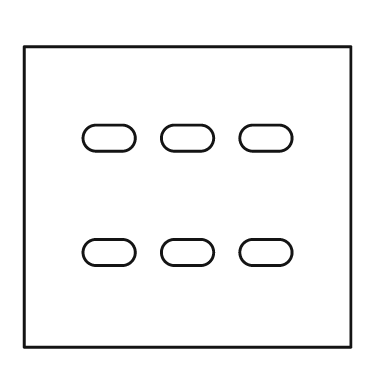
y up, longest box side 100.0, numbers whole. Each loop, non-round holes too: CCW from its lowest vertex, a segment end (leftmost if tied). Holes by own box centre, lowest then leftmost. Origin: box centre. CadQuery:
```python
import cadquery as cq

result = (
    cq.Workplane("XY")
    .moveTo(-50.0, -46.0)
    .lineTo(50.0, -46.0)
    .lineTo(50.0, 46.0)
    .lineTo(-50.0, 46.0)
    .close()
    .moveTo(-28.0, -21.0)
    .lineTo(-20.0, -21.0)
    .threePointArc((-16.0, -17.0), (-20.0, -13.0))
    .lineTo(-28.0, -13.0)
    .threePointArc((-32.0, -17.0), (-28.0, -21.0))
    .close()
    .moveTo(-4.0, -21.0)
    .lineTo(4.0, -21.0)
    .threePointArc((8.0, -17.0), (4.0, -13.0))
    .lineTo(-4.0, -13.0)
    .threePointArc((-8.0, -17.0), (-4.0, -21.0))
    .close()
    .moveTo(20.0, -21.0)
    .lineTo(28.0, -21.0)
    .threePointArc((32.0, -17.0), (28.0, -13.0))
    .lineTo(20.0, -13.0)
    .threePointArc((16.0, -17.0), (20.0, -21.0))
    .close()
    .moveTo(-28.0, 14.0)
    .lineTo(-20.0, 14.0)
    .threePointArc((-16.0, 18.0), (-20.0, 22.0))
    .lineTo(-28.0, 22.0)
    .threePointArc((-32.0, 18.0), (-28.0, 14.0))
    .close()
    .moveTo(-4.0, 14.0)
    .lineTo(4.0, 14.0)
    .threePointArc((8.0, 18.0), (4.0, 22.0))
    .lineTo(-4.0, 22.0)
    .threePointArc((-8.0, 18.0), (-4.0, 14.0))
    .close()
    .moveTo(20.0, 14.0)
    .lineTo(28.0, 14.0)
    .threePointArc((32.0, 18.0), (28.0, 22.0))
    .lineTo(20.0, 22.0)
    .threePointArc((16.0, 18.0), (20.0, 14.0))
    .close()
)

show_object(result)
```